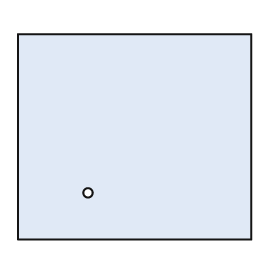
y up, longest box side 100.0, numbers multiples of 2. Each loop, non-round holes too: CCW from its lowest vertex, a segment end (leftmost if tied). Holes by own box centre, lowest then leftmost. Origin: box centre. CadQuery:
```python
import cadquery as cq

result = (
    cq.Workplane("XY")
    .moveTo(-50.0, -44.0)
    .lineTo(50.0, -44.0)
    .lineTo(50.0, 44.0)
    .lineTo(-50.0, 44.0)
    .close()
    .moveTo(-20.0, -24.0)
    .circle(2.0)
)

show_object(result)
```